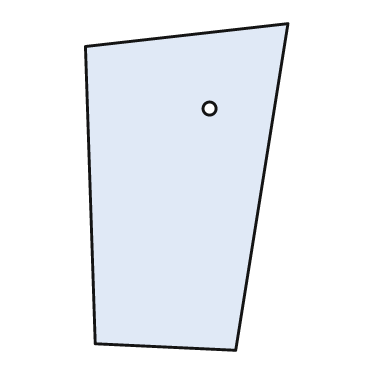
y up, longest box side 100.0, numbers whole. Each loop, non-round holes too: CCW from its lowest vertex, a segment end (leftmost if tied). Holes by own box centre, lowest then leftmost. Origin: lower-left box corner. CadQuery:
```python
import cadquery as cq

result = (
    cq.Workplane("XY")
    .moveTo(46.0, 0.0)
    .lineTo(62.0, 100.0)
    .lineTo(0.0, 93.0)
    .lineTo(3.0, 2.0)
    .close()
    .moveTo(38.0, 74.0)
    .circle(2.0)
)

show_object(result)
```